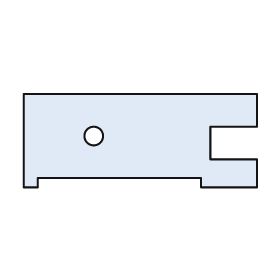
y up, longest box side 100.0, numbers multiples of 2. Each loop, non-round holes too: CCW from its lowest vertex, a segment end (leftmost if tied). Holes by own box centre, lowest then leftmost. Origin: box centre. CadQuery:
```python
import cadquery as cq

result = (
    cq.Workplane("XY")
    .moveTo(-50.0, -20.0)
    .lineTo(-44.0, -20.0)
    .lineTo(-44.0, -16.0)
    .lineTo(26.0, -16.0)
    .lineTo(26.0, -20.0)
    .lineTo(50.0, -20.0)
    .lineTo(50.0, -8.0)
    .lineTo(30.0, -8.0)
    .lineTo(30.0, 6.0)
    .lineTo(50.0, 6.0)
    .lineTo(50.0, 20.0)
    .lineTo(-50.0, 20.0)
    .close()
    .moveTo(-20.0, 2.0)
    .circle(4.0)
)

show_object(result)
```